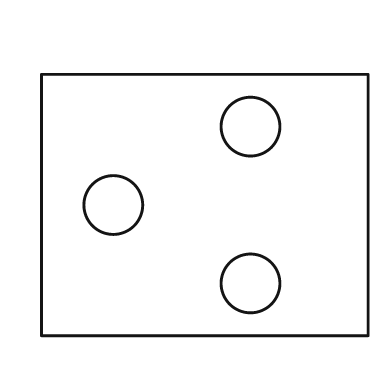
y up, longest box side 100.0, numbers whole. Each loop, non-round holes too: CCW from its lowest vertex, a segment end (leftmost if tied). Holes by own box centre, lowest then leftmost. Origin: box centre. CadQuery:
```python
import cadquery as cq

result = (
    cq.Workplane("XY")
    .moveTo(-50.0, -40.0)
    .lineTo(50.0, -40.0)
    .lineTo(50.0, 40.0)
    .lineTo(-50.0, 40.0)
    .close()
    .moveTo(14.0, -24.0)
    .circle(9.0)
    .moveTo(-28.0, 0.0)
    .circle(9.0)
    .moveTo(14.0, 24.0)
    .circle(9.0)
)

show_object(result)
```